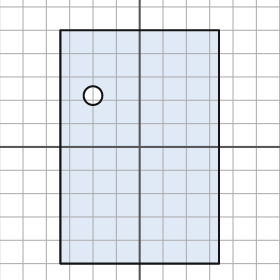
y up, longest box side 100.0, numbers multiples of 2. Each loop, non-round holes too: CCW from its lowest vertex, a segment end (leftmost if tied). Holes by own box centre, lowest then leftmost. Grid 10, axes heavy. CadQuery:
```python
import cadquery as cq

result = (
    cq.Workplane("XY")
    .moveTo(-34.0, -50.0)
    .lineTo(34.0, -50.0)
    .lineTo(34.0, 50.0)
    .lineTo(-34.0, 50.0)
    .close()
    .moveTo(-20.0, 22.0)
    .circle(4.0)
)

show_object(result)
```